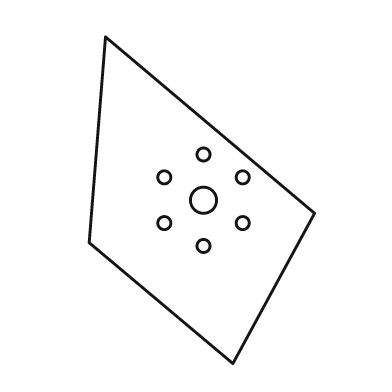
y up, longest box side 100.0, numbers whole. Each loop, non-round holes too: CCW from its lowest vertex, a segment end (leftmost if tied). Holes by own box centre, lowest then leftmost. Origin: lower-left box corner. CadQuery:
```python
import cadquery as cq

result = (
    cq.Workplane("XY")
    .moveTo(44.0, 0.0)
    .lineTo(69.0, 46.0)
    .lineTo(5.0, 100.0)
    .lineTo(0.0, 37.0)
    .close()
    .moveTo(35.0, 36.0)
    .circle(2.0)
    .moveTo(23.0, 43.0)
    .circle(2.0)
    .moveTo(47.0, 43.0)
    .circle(2.0)
    .moveTo(35.0, 50.0)
    .circle(4.0)
    .moveTo(23.0, 57.0)
    .circle(2.0)
    .moveTo(47.0, 57.0)
    .circle(2.0)
    .moveTo(35.0, 64.0)
    .circle(2.0)
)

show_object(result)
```